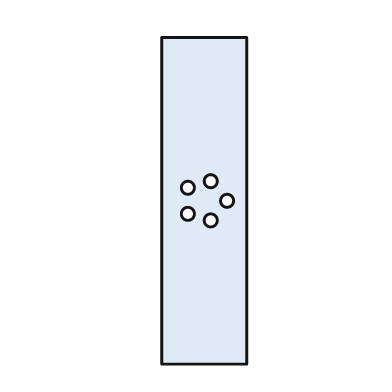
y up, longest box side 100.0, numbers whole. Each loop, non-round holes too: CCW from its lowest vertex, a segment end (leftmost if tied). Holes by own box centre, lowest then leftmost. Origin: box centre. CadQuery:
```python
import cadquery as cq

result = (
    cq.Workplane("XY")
    .moveTo(-13.0, -50.0)
    .lineTo(13.0, -50.0)
    .lineTo(13.0, 50.0)
    .lineTo(-13.0, 50.0)
    .close()
    .moveTo(2.0, -6.0)
    .circle(2.0)
    .moveTo(-5.0, -4.0)
    .circle(2.0)
    .moveTo(7.0, 0.0)
    .circle(2.0)
    .moveTo(-5.0, 4.0)
    .circle(2.0)
    .moveTo(2.0, 6.0)
    .circle(2.0)
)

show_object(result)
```